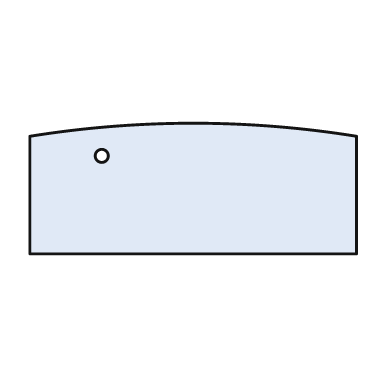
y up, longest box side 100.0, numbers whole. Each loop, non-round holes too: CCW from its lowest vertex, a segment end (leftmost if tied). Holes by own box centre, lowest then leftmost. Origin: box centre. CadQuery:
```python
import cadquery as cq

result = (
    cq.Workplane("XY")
    .moveTo(-50.0, -20.0)
    .lineTo(50.0, -20.0)
    .lineTo(50.0, 16.0)
    .threePointArc((0.0, 20.0), (-50.0, 16.0))
    .close()
    .moveTo(-28.0, 10.0)
    .circle(2.0)
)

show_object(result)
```